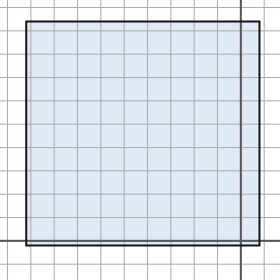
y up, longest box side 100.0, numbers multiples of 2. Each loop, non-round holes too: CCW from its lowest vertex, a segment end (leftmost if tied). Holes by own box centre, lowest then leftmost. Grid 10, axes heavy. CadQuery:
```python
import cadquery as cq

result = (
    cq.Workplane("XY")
    .moveTo(-92.0, -2.0)
    .lineTo(8.0, -2.0)
    .lineTo(8.0, 94.0)
    .lineTo(-92.0, 94.0)
    .close()
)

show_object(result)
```